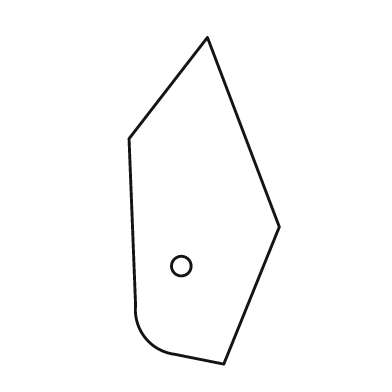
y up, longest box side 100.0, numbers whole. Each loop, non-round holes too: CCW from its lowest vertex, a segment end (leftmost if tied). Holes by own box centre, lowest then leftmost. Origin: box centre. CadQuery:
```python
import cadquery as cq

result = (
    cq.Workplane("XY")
    .moveTo(6.0, -50.0)
    .lineTo(23.0, -8.0)
    .lineTo(1.0, 50.0)
    .lineTo(-23.0, 19.0)
    .lineTo(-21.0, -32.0)
    .threePointArc((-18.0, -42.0), (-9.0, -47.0))
    .close()
    .moveTo(-7.0, -20.0)
    .circle(3.0)
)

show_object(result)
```